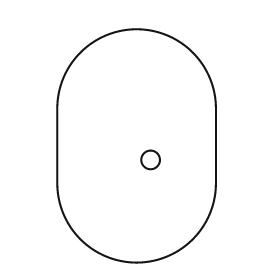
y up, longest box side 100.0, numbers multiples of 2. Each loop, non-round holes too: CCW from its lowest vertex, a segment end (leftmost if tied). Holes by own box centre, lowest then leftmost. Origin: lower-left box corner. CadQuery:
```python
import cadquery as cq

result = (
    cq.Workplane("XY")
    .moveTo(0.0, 34.0)
    .threePointArc((34.0, 0.0), (68.0, 34.0))
    .lineTo(68.0, 66.0)
    .threePointArc((34.0, 100.0), (0.0, 66.0))
    .close()
    .moveTo(40.0, 44.0)
    .circle(4.0)
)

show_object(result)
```